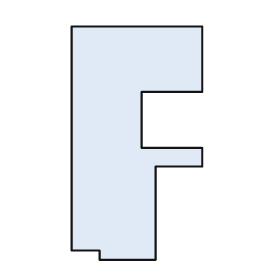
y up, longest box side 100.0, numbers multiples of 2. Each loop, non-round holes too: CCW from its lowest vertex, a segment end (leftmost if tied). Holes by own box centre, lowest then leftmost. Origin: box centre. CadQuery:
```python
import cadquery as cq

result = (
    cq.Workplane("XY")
    .moveTo(-16.0, -50.0)
    .lineTo(8.0, -50.0)
    .lineTo(8.0, -10.0)
    .lineTo(28.0, -10.0)
    .lineTo(28.0, -2.0)
    .lineTo(2.0, -2.0)
    .lineTo(2.0, 22.0)
    .lineTo(28.0, 22.0)
    .lineTo(28.0, 50.0)
    .lineTo(-28.0, 50.0)
    .lineTo(-28.0, -46.0)
    .lineTo(-16.0, -46.0)
    .close()
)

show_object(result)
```